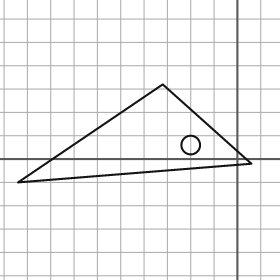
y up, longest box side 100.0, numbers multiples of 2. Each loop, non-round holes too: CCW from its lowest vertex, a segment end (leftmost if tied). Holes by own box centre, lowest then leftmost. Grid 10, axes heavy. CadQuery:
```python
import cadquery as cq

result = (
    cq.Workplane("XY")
    .moveTo(-94.0, -10.0)
    .lineTo(6.0, -2.0)
    .lineTo(-32.0, 32.0)
    .close()
    .moveTo(-20.0, 6.0)
    .circle(4.0)
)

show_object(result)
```